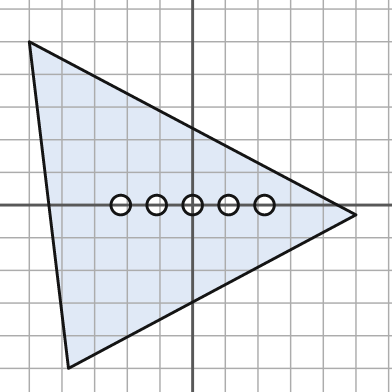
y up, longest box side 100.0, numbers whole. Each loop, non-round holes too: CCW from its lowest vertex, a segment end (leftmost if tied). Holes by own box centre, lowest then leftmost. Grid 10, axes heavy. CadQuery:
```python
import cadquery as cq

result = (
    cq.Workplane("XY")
    .moveTo(-38.0, -50.0)
    .lineTo(50.0, -3.0)
    .lineTo(-50.0, 50.0)
    .close()
    .moveTo(-22.0, 0.0)
    .circle(3.0)
    .moveTo(-11.0, 0.0)
    .circle(3.0)
    .moveTo(0.0, 0.0)
    .circle(3.0)
    .moveTo(11.0, 0.0)
    .circle(3.0)
    .moveTo(22.0, 0.0)
    .circle(3.0)
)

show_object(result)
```